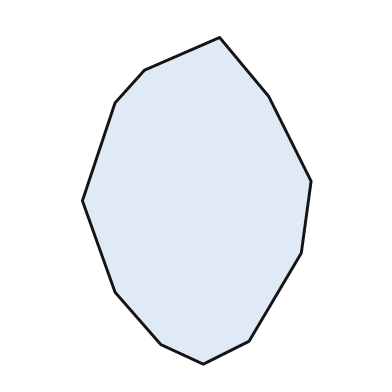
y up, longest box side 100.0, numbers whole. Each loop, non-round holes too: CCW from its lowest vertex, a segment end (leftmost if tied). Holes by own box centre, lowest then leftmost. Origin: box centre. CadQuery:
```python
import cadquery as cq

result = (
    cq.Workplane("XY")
    .moveTo(2.0, -50.0)
    .lineTo(16.0, -43.0)
    .lineTo(32.0, -16.0)
    .lineTo(35.0, 6.0)
    .lineTo(22.0, 32.0)
    .lineTo(7.0, 50.0)
    .lineTo(-16.0, 40.0)
    .lineTo(-25.0, 30.0)
    .lineTo(-35.0, 0.0)
    .lineTo(-25.0, -28.0)
    .lineTo(-11.0, -44.0)
    .close()
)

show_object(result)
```